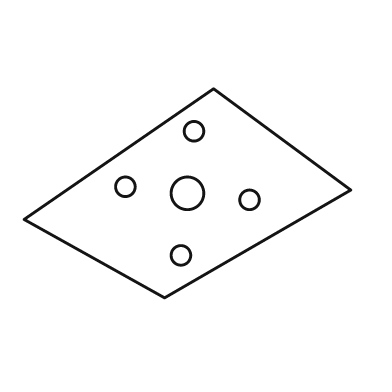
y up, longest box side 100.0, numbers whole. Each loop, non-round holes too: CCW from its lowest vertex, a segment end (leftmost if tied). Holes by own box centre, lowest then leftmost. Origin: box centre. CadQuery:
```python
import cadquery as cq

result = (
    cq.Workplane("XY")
    .moveTo(-7.0, -32.0)
    .lineTo(50.0, 1.0)
    .lineTo(8.0, 32.0)
    .lineTo(-50.0, -8.0)
    .close()
    .moveTo(-2.0, -19.0)
    .circle(3.0)
    .moveTo(19.0, -2.0)
    .circle(3.0)
    .moveTo(0.0, 0.0)
    .circle(5.0)
    .moveTo(-19.0, 2.0)
    .circle(3.0)
    .moveTo(2.0, 19.0)
    .circle(3.0)
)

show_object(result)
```